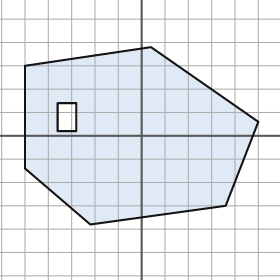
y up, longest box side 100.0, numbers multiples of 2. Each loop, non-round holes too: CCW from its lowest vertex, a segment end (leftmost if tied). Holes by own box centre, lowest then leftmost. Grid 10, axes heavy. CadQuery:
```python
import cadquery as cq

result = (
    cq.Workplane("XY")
    .moveTo(-22.0, -38.0)
    .lineTo(36.0, -30.0)
    .lineTo(50.0, 6.0)
    .lineTo(4.0, 38.0)
    .lineTo(-50.0, 30.0)
    .lineTo(-50.0, -14.0)
    .close()
    .moveTo(-36.0, 2.0)
    .lineTo(-28.0, 2.0)
    .lineTo(-28.0, 14.0)
    .lineTo(-36.0, 14.0)
    .close()
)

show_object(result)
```